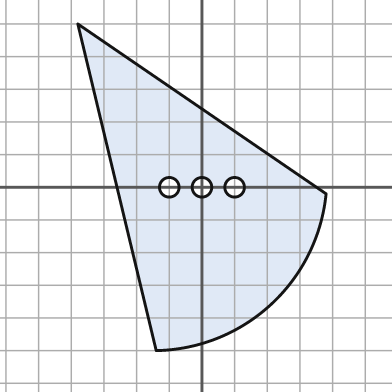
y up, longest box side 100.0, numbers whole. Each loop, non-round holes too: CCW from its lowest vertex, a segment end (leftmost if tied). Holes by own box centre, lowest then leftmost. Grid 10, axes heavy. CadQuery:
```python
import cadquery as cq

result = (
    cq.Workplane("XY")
    .moveTo(-14.0, -50.0)
    .threePointArc((21.0, -36.0), (38.0, -2.0))
    .lineTo(-38.0, 50.0)
    .close()
    .moveTo(-10.0, 0.0)
    .circle(3.0)
    .moveTo(0.0, 0.0)
    .circle(3.0)
    .moveTo(10.0, 0.0)
    .circle(3.0)
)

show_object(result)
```